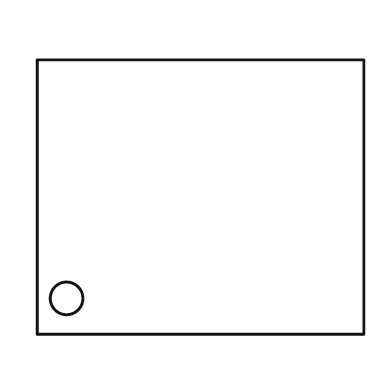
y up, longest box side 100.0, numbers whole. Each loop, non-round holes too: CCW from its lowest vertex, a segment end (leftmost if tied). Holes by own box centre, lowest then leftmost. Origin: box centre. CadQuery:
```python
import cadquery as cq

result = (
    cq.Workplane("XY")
    .moveTo(-50.0, -42.0)
    .lineTo(50.0, -42.0)
    .lineTo(50.0, 42.0)
    .lineTo(-50.0, 42.0)
    .close()
    .moveTo(-41.0, -31.0)
    .circle(5.0)
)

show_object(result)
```